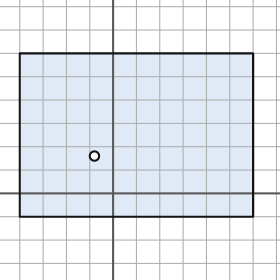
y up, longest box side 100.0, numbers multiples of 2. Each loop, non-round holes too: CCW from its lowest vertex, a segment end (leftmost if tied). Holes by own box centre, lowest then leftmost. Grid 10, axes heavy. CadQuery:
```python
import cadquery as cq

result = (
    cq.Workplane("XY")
    .moveTo(-40.0, -10.0)
    .lineTo(60.0, -10.0)
    .lineTo(60.0, 60.0)
    .lineTo(-40.0, 60.0)
    .close()
    .moveTo(-8.0, 16.0)
    .circle(2.0)
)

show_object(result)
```